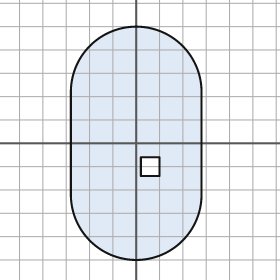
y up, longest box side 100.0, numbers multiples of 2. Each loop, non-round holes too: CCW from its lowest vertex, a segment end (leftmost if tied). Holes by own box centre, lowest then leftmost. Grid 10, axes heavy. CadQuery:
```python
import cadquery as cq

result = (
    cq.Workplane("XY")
    .moveTo(-28.0, -22.0)
    .threePointArc((0.0, -50.0), (28.0, -22.0))
    .lineTo(28.0, 22.0)
    .threePointArc((0.0, 50.0), (-28.0, 22.0))
    .close()
    .moveTo(2.0, -14.0)
    .lineTo(10.0, -14.0)
    .lineTo(10.0, -6.0)
    .lineTo(2.0, -6.0)
    .close()
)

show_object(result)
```